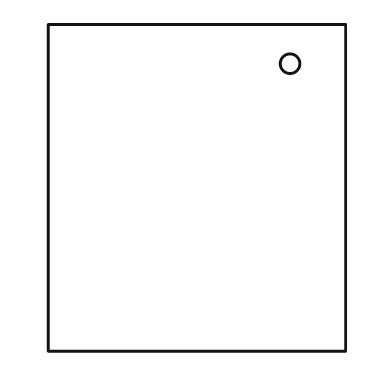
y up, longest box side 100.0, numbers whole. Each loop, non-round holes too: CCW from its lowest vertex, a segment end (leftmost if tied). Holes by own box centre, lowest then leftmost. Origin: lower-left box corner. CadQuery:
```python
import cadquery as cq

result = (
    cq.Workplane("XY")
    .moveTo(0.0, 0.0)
    .lineTo(91.0, 0.0)
    .lineTo(91.0, 100.0)
    .lineTo(0.0, 100.0)
    .close()
    .moveTo(74.0, 88.0)
    .circle(3.0)
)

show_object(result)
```